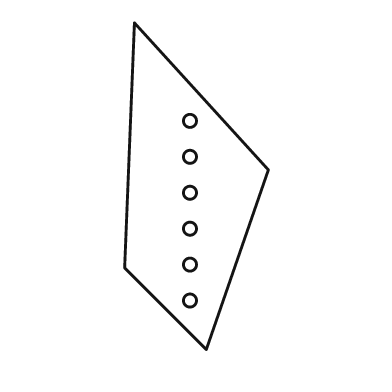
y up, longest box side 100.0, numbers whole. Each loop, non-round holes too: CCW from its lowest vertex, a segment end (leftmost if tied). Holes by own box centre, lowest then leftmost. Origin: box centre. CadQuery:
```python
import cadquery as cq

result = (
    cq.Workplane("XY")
    .moveTo(3.0, -50.0)
    .lineTo(22.0, 5.0)
    .lineTo(-19.0, 50.0)
    .lineTo(-22.0, -25.0)
    .close()
    .moveTo(-2.0, -35.0)
    .circle(2.0)
    .moveTo(-2.0, -24.0)
    .circle(2.0)
    .moveTo(-2.0, -13.0)
    .circle(2.0)
    .moveTo(-2.0, -2.0)
    .circle(2.0)
    .moveTo(-2.0, 9.0)
    .circle(2.0)
    .moveTo(-2.0, 20.0)
    .circle(2.0)
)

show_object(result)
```